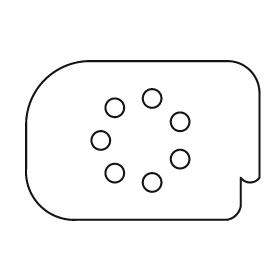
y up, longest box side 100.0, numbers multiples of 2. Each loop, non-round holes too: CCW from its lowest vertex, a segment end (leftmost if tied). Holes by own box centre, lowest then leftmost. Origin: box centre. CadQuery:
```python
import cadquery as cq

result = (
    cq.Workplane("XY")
    .moveTo(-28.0, -34.0)
    .lineTo(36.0, -34.0)
    .threePointArc((40.0, -32.0), (42.0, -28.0))
    .lineTo(42.0, -16.0)
    .threePointArc((46.0, -18.0), (50.0, -16.0))
    .lineTo(50.0, 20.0)
    .threePointArc((46.0, 30.0), (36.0, 34.0))
    .lineTo(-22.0, 34.0)
    .threePointArc((-42.0, 26.0), (-50.0, 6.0))
    .lineTo(-50.0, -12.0)
    .threePointArc((-44.0, -28.0), (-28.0, -34.0))
    .close()
    .moveTo(4.0, -18.0)
    .circle(4.0)
    .moveTo(-12.0, -14.0)
    .circle(4.0)
    .moveTo(16.0, -8.0)
    .circle(4.0)
    .moveTo(-18.0, 0.0)
    .circle(4.0)
    .moveTo(16.0, 8.0)
    .circle(4.0)
    .moveTo(-12.0, 14.0)
    .circle(4.0)
    .moveTo(4.0, 18.0)
    .circle(4.0)
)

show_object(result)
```